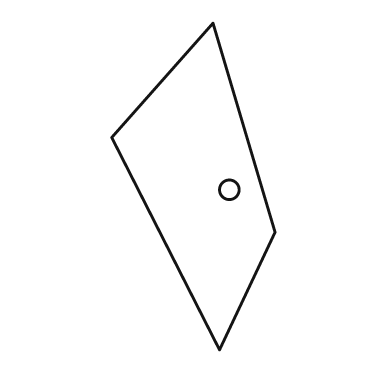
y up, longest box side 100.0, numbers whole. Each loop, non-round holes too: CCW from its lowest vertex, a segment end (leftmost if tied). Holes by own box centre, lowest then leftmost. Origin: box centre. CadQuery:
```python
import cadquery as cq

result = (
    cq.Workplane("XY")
    .moveTo(8.0, -50.0)
    .lineTo(25.0, -14.0)
    .lineTo(6.0, 50.0)
    .lineTo(-25.0, 15.0)
    .close()
    .moveTo(11.0, -1.0)
    .circle(3.0)
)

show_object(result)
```